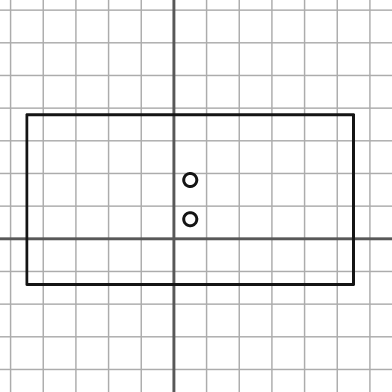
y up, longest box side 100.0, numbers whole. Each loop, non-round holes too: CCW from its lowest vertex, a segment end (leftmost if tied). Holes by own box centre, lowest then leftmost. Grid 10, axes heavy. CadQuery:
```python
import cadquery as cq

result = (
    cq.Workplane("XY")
    .moveTo(-45.0, -14.0)
    .lineTo(55.0, -14.0)
    .lineTo(55.0, 38.0)
    .lineTo(-45.0, 38.0)
    .close()
    .moveTo(5.0, 6.0)
    .circle(2.0)
    .moveTo(5.0, 18.0)
    .circle(2.0)
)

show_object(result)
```